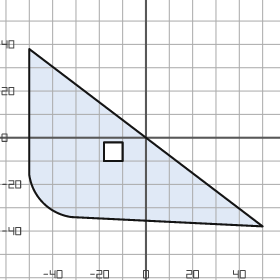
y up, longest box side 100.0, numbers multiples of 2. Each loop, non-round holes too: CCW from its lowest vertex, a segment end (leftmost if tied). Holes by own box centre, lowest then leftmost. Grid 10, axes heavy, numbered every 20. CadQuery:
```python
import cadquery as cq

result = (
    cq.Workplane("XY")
    .moveTo(50.0, -38.0)
    .lineTo(-50.0, 38.0)
    .lineTo(-50.0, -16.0)
    .threePointArc((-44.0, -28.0), (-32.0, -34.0))
    .close()
    .moveTo(-18.0, -10.0)
    .lineTo(-10.0, -10.0)
    .lineTo(-10.0, -2.0)
    .lineTo(-18.0, -2.0)
    .close()
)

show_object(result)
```